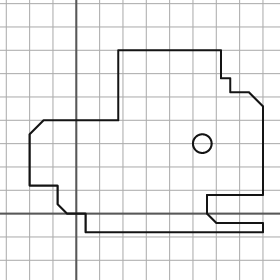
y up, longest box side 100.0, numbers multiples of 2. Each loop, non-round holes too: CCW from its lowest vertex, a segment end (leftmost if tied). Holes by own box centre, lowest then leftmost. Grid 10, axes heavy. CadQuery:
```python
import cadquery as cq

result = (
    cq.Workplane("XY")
    .moveTo(4.0, -8.0)
    .lineTo(80.0, -8.0)
    .lineTo(80.0, -4.0)
    .lineTo(60.0, -4.0)
    .lineTo(56.0, 0.0)
    .lineTo(56.0, 8.0)
    .lineTo(80.0, 8.0)
    .lineTo(80.0, 46.0)
    .lineTo(74.0, 52.0)
    .lineTo(66.0, 52.0)
    .lineTo(66.0, 58.0)
    .lineTo(62.0, 58.0)
    .lineTo(62.0, 70.0)
    .lineTo(18.0, 70.0)
    .lineTo(18.0, 40.0)
    .lineTo(-14.0, 40.0)
    .lineTo(-20.0, 34.0)
    .lineTo(-20.0, 12.0)
    .lineTo(-8.0, 12.0)
    .lineTo(-8.0, 4.0)
    .lineTo(-4.0, 0.0)
    .lineTo(4.0, 0.0)
    .close()
    .moveTo(54.0, 30.0)
    .circle(4.0)
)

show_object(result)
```